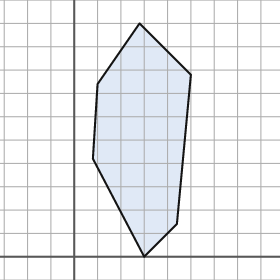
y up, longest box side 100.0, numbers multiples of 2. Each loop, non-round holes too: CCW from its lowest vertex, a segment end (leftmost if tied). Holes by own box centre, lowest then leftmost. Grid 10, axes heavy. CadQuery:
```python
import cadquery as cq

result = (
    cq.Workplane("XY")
    .moveTo(30.0, 0.0)
    .lineTo(44.0, 14.0)
    .lineTo(50.0, 78.0)
    .lineTo(28.0, 100.0)
    .lineTo(10.0, 74.0)
    .lineTo(8.0, 42.0)
    .close()
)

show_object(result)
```